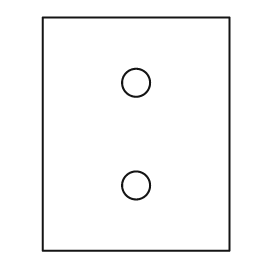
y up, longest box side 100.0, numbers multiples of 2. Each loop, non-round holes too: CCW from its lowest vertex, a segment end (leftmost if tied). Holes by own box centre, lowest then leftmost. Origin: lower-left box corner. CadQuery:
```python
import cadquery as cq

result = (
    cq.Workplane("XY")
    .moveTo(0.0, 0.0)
    .lineTo(80.0, 0.0)
    .lineTo(80.0, 100.0)
    .lineTo(0.0, 100.0)
    .close()
    .moveTo(40.0, 28.0)
    .circle(6.0)
    .moveTo(40.0, 72.0)
    .circle(6.0)
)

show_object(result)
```